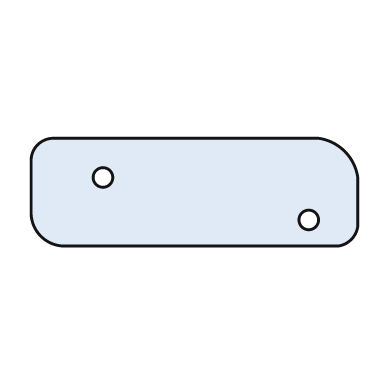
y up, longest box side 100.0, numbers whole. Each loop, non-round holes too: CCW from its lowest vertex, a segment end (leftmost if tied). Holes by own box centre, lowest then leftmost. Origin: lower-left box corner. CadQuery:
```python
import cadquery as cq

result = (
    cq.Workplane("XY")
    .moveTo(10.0, 0.0)
    .lineTo(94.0, 0.0)
    .threePointArc((98.0, 2.0), (100.0, 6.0))
    .lineTo(100.0, 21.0)
    .threePointArc((96.0, 29.0), (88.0, 33.0))
    .lineTo(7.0, 33.0)
    .threePointArc((2.0, 31.0), (0.0, 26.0))
    .lineTo(0.0, 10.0)
    .threePointArc((3.0, 3.0), (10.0, 0.0))
    .close()
    .moveTo(85.0, 8.0)
    .circle(3.0)
    .moveTo(22.0, 21.0)
    .circle(3.0)
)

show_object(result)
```